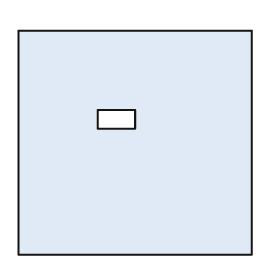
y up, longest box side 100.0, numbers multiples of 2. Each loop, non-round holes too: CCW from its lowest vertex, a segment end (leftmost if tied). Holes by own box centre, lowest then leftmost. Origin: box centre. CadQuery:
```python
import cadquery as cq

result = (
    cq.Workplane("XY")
    .moveTo(-50.0, -48.0)
    .lineTo(50.0, -48.0)
    .lineTo(50.0, 48.0)
    .lineTo(-50.0, 48.0)
    .close()
    .moveTo(-16.0, 6.0)
    .lineTo(0.0, 6.0)
    .lineTo(0.0, 14.0)
    .lineTo(-16.0, 14.0)
    .close()
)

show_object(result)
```